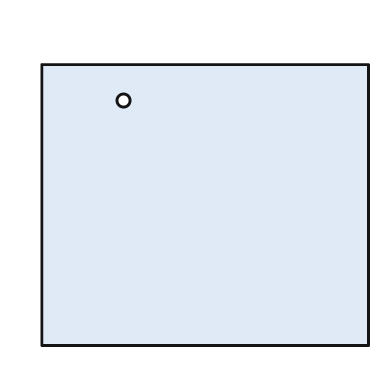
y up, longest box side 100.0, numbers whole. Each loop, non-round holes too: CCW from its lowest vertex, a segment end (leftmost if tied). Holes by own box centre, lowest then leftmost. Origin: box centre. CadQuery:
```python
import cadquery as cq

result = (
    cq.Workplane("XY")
    .moveTo(-50.0, -43.0)
    .lineTo(50.0, -43.0)
    .lineTo(50.0, 43.0)
    .lineTo(-50.0, 43.0)
    .close()
    .moveTo(-25.0, 32.0)
    .circle(2.0)
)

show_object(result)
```